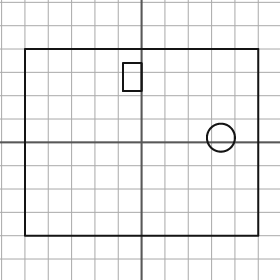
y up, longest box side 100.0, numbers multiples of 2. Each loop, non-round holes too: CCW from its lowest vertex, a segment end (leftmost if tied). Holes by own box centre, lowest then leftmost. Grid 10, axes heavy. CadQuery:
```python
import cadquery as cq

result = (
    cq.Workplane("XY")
    .moveTo(-50.0, -40.0)
    .lineTo(50.0, -40.0)
    .lineTo(50.0, 40.0)
    .lineTo(-50.0, 40.0)
    .close()
    .moveTo(34.0, 2.0)
    .circle(6.0)
    .moveTo(-8.0, 22.0)
    .lineTo(0.0, 22.0)
    .lineTo(0.0, 34.0)
    .lineTo(-8.0, 34.0)
    .close()
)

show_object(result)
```